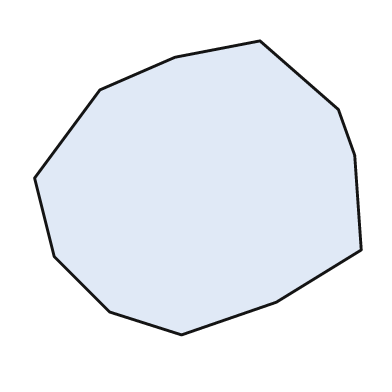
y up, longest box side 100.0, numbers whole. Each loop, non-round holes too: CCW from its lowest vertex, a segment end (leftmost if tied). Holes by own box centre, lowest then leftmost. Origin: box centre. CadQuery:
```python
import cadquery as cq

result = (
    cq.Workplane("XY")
    .moveTo(-5.0, -45.0)
    .lineTo(24.0, -35.0)
    .lineTo(50.0, -19.0)
    .lineTo(48.0, 10.0)
    .lineTo(43.0, 24.0)
    .lineTo(19.0, 45.0)
    .lineTo(-7.0, 40.0)
    .lineTo(-30.0, 30.0)
    .lineTo(-50.0, 3.0)
    .lineTo(-44.0, -21.0)
    .lineTo(-27.0, -38.0)
    .close()
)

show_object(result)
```